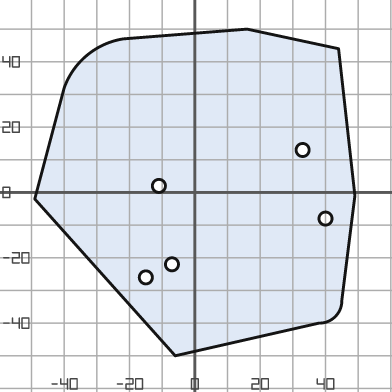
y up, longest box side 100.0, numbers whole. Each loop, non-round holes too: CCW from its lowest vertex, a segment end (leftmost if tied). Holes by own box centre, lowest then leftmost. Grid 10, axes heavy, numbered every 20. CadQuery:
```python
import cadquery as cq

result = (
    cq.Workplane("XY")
    .moveTo(-6.0, -50.0)
    .lineTo(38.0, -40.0)
    .threePointArc((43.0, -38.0), (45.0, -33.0))
    .lineTo(49.0, -1.0)
    .lineTo(44.0, 44.0)
    .lineTo(16.0, 50.0)
    .lineTo(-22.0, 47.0)
    .threePointArc((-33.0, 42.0), (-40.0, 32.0))
    .lineTo(-49.0, -2.0)
    .close()
    .moveTo(-15.0, -26.0)
    .circle(2.0)
    .moveTo(-7.0, -22.0)
    .circle(2.0)
    .moveTo(40.0, -8.0)
    .circle(2.0)
    .moveTo(-11.0, 2.0)
    .circle(2.0)
    .moveTo(33.0, 13.0)
    .circle(2.0)
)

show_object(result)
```